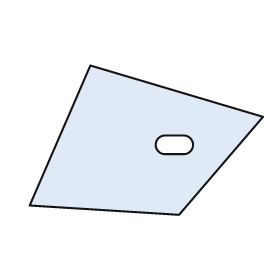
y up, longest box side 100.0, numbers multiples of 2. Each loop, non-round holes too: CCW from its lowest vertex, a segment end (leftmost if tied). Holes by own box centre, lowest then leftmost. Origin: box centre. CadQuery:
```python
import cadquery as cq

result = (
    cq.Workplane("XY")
    .moveTo(14.0, -32.0)
    .lineTo(50.0, 10.0)
    .lineTo(-24.0, 32.0)
    .lineTo(-50.0, -28.0)
    .close()
    .moveTo(8.0, -6.0)
    .lineTo(16.0, -6.0)
    .threePointArc((20.0, -2.0), (16.0, 2.0))
    .lineTo(8.0, 2.0)
    .threePointArc((4.0, -2.0), (8.0, -6.0))
    .close()
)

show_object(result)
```